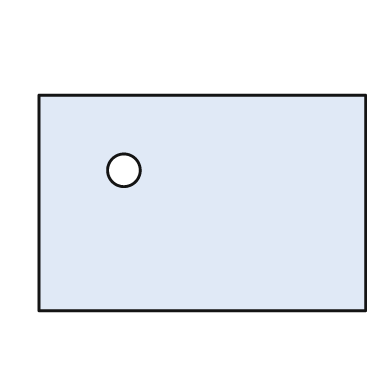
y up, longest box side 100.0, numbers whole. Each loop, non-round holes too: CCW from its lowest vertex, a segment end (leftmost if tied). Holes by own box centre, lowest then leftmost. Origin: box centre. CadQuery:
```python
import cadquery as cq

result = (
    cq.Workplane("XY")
    .moveTo(-50.0, -33.0)
    .lineTo(50.0, -33.0)
    .lineTo(50.0, 33.0)
    .lineTo(-50.0, 33.0)
    .close()
    .moveTo(-24.0, 10.0)
    .circle(5.0)
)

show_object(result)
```